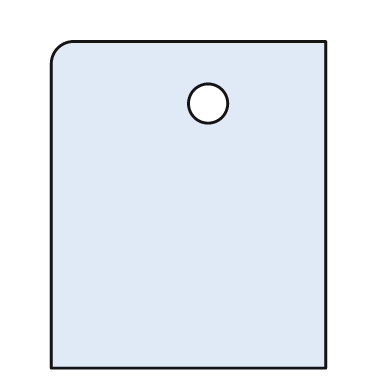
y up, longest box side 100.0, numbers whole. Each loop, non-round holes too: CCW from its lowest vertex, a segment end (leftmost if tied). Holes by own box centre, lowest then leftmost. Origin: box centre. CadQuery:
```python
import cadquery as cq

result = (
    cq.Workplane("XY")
    .moveTo(-42.0, -50.0)
    .lineTo(42.0, -50.0)
    .lineTo(42.0, 50.0)
    .lineTo(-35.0, 50.0)
    .threePointArc((-40.0, 48.0), (-42.0, 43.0))
    .close()
    .moveTo(6.0, 31.0)
    .circle(6.0)
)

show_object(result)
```